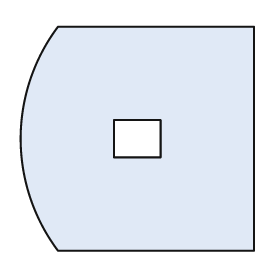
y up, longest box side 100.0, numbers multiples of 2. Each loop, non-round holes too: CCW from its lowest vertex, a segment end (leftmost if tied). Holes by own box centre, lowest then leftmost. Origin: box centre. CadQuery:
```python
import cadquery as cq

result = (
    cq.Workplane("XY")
    .moveTo(-34.0, -48.0)
    .lineTo(50.0, -48.0)
    .lineTo(50.0, 48.0)
    .lineTo(-34.0, 48.0)
    .threePointArc((-50.0, 0.0), (-34.0, -48.0))
    .close()
    .moveTo(-10.0, -8.0)
    .lineTo(10.0, -8.0)
    .lineTo(10.0, 8.0)
    .lineTo(-10.0, 8.0)
    .close()
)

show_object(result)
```